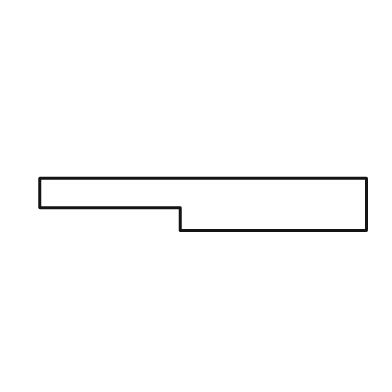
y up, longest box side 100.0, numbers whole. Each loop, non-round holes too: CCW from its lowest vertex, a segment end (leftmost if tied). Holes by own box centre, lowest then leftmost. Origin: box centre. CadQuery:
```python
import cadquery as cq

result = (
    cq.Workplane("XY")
    .moveTo(-7.0, -8.0)
    .lineTo(50.0, -8.0)
    .lineTo(50.0, 8.0)
    .lineTo(-50.0, 8.0)
    .lineTo(-50.0, -1.0)
    .lineTo(-7.0, -1.0)
    .close()
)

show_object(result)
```